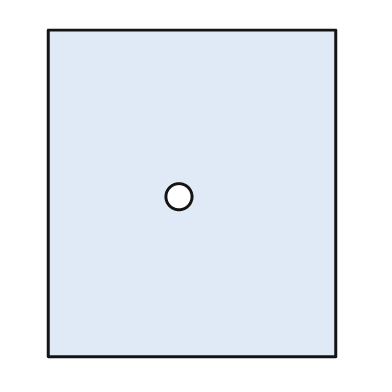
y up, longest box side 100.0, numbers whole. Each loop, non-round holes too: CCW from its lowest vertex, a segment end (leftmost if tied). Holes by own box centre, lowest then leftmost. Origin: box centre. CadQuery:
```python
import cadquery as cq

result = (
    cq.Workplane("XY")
    .moveTo(-44.0, -50.0)
    .lineTo(44.0, -50.0)
    .lineTo(44.0, 50.0)
    .lineTo(-44.0, 50.0)
    .close()
    .moveTo(-4.0, -1.0)
    .circle(4.0)
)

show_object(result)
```